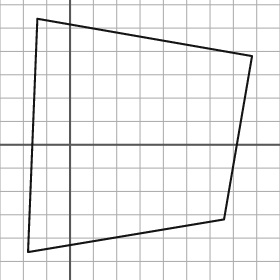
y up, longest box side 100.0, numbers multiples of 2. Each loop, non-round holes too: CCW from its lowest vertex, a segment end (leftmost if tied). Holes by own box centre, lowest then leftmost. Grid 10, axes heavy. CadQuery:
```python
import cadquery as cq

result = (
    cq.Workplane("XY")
    .moveTo(-18.0, -46.0)
    .lineTo(66.0, -32.0)
    .lineTo(78.0, 38.0)
    .lineTo(-14.0, 54.0)
    .close()
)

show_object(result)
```